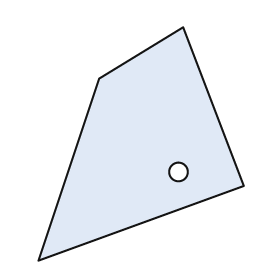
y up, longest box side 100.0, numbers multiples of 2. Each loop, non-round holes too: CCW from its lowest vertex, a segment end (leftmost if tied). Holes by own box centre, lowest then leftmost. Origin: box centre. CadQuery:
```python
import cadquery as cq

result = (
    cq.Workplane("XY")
    .moveTo(-44.0, -50.0)
    .lineTo(44.0, -18.0)
    .lineTo(18.0, 50.0)
    .lineTo(-18.0, 28.0)
    .close()
    .moveTo(16.0, -12.0)
    .circle(4.0)
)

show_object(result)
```